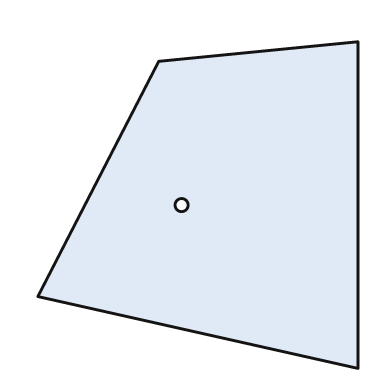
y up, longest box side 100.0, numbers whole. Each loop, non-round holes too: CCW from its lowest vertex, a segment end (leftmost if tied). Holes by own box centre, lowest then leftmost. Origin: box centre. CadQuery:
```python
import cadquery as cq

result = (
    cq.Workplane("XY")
    .moveTo(49.0, -50.0)
    .lineTo(49.0, 50.0)
    .lineTo(-12.0, 44.0)
    .lineTo(-49.0, -28.0)
    .close()
    .moveTo(-5.0, 0.0)
    .circle(2.0)
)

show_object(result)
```